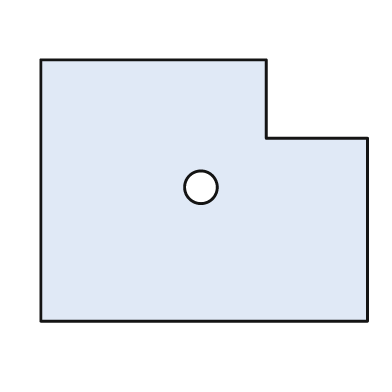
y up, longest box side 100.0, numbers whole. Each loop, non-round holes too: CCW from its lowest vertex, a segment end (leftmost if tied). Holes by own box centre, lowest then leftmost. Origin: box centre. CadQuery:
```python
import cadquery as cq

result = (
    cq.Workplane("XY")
    .moveTo(-50.0, -40.0)
    .lineTo(50.0, -40.0)
    .lineTo(50.0, 16.0)
    .lineTo(19.0, 16.0)
    .lineTo(19.0, 40.0)
    .lineTo(-50.0, 40.0)
    .close()
    .moveTo(-1.0, 1.0)
    .circle(5.0)
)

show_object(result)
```